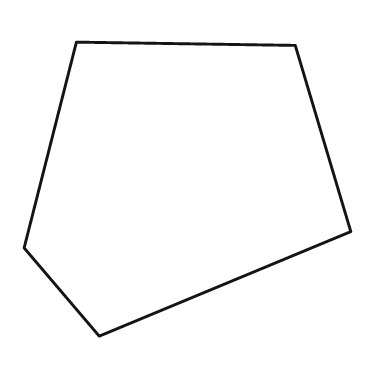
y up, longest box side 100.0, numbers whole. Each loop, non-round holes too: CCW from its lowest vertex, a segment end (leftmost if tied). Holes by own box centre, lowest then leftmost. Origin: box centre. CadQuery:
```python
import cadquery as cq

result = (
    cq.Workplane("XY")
    .moveTo(-27.0, -45.0)
    .lineTo(50.0, -13.0)
    .lineTo(33.0, 44.0)
    .lineTo(-34.0, 45.0)
    .lineTo(-50.0, -18.0)
    .close()
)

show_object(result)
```